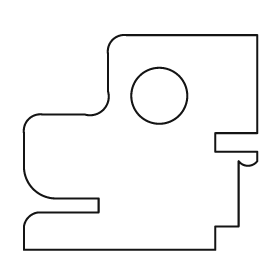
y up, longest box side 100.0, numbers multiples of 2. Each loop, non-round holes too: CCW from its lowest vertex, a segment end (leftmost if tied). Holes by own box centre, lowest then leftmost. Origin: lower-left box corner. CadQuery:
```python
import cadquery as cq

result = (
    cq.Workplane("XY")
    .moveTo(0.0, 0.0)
    .lineTo(82.0, 0.0)
    .lineTo(82.0, 10.0)
    .lineTo(92.0, 10.0)
    .lineTo(92.0, 38.0)
    .threePointArc((96.0, 36.0), (100.0, 38.0))
    .lineTo(100.0, 42.0)
    .lineTo(82.0, 42.0)
    .lineTo(82.0, 50.0)
    .lineTo(100.0, 50.0)
    .lineTo(100.0, 92.0)
    .lineTo(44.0, 92.0)
    .threePointArc((38.0, 90.0), (36.0, 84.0))
    .lineTo(36.0, 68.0)
    .threePointArc((34.0, 60.0), (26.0, 58.0))
    .lineTo(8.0, 58.0)
    .threePointArc((2.0, 56.0), (0.0, 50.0))
    .lineTo(0.0, 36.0)
    .threePointArc((4.0, 26.0), (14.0, 22.0))
    .lineTo(32.0, 22.0)
    .lineTo(32.0, 16.0)
    .lineTo(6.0, 16.0)
    .threePointArc((2.0, 14.0), (0.0, 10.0))
    .close()
    .moveTo(58.0, 66.0)
    .circle(12.0)
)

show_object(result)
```